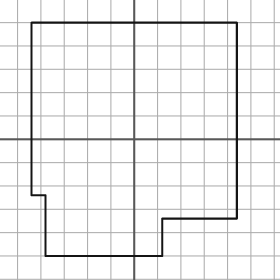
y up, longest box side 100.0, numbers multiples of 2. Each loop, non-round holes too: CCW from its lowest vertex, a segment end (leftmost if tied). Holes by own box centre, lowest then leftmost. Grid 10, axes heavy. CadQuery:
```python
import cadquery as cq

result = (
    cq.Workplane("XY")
    .moveTo(-38.0, -50.0)
    .lineTo(12.0, -50.0)
    .lineTo(12.0, -34.0)
    .lineTo(44.0, -34.0)
    .lineTo(44.0, 50.0)
    .lineTo(-44.0, 50.0)
    .lineTo(-44.0, -24.0)
    .lineTo(-38.0, -24.0)
    .close()
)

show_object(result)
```